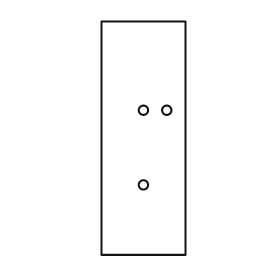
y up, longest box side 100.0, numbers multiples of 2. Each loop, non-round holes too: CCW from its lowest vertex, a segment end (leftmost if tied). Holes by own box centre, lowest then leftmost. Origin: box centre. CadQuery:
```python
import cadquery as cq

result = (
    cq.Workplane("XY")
    .moveTo(-18.0, -50.0)
    .lineTo(18.0, -50.0)
    .lineTo(18.0, 50.0)
    .lineTo(-18.0, 50.0)
    .close()
    .moveTo(0.0, -20.0)
    .circle(2.0)
    .moveTo(0.0, 12.0)
    .circle(2.0)
    .moveTo(10.0, 12.0)
    .circle(2.0)
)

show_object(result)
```